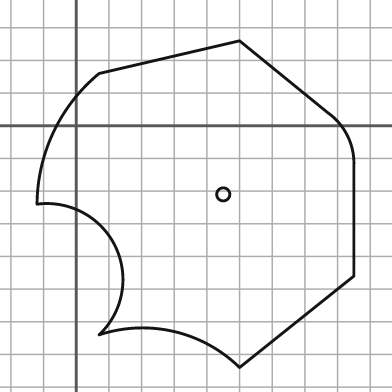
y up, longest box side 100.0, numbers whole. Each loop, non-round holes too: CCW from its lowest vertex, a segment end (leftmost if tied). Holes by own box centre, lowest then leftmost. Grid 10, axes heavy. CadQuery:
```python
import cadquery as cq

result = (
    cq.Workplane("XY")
    .moveTo(50.0, -74.0)
    .lineTo(85.0, -46.0)
    .lineTo(85.0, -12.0)
    .threePointArc((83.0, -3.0), (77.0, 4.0))
    .lineTo(50.0, 26.0)
    .lineTo(7.0, 16.0)
    .threePointArc((-7.0, -2.0), (-12.0, -24.0))
    .threePointArc((12.0, -37.0), (7.0, -64.0))
    .threePointArc((30.0, -63.0), (50.0, -74.0))
    .close()
    .moveTo(45.0, -21.0)
    .circle(2.0)
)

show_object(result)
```